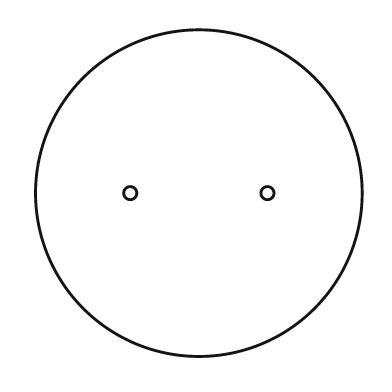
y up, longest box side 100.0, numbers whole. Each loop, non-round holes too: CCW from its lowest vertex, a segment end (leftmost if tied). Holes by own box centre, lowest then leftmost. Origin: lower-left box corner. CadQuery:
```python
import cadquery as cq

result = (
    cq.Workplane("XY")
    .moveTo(50.0, 50.0)
    .circle(50.0)
    .moveTo(29.0, 50.0)
    .circle(2.0)
    .moveTo(71.0, 50.0)
    .circle(2.0)
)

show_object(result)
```